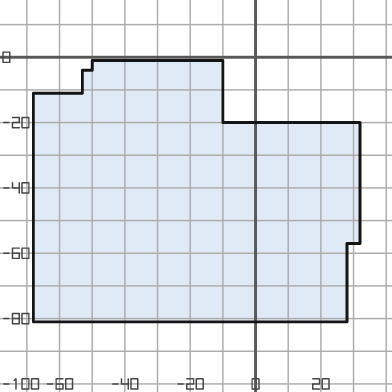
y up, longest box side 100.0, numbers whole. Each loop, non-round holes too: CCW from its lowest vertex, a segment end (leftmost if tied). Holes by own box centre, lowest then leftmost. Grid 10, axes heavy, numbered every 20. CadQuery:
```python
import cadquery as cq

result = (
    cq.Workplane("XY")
    .moveTo(-68.0, -81.0)
    .lineTo(28.0, -81.0)
    .lineTo(28.0, -57.0)
    .lineTo(32.0, -57.0)
    .lineTo(32.0, -20.0)
    .lineTo(-10.0, -20.0)
    .lineTo(-10.0, -1.0)
    .lineTo(-50.0, -1.0)
    .lineTo(-50.0, -4.0)
    .lineTo(-53.0, -4.0)
    .lineTo(-53.0, -11.0)
    .lineTo(-68.0, -11.0)
    .close()
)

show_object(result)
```